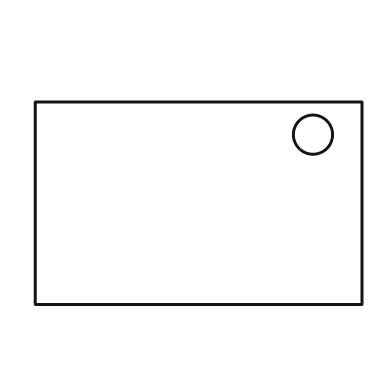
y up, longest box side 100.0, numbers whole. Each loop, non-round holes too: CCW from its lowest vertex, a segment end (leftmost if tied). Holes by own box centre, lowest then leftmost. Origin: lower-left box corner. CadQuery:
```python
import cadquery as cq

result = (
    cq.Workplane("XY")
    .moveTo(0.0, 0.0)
    .lineTo(100.0, 0.0)
    .lineTo(100.0, 62.0)
    .lineTo(0.0, 62.0)
    .close()
    .moveTo(85.0, 52.0)
    .circle(6.0)
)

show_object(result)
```